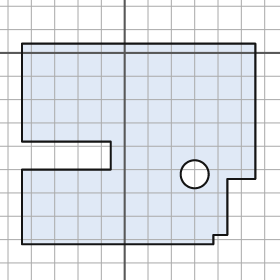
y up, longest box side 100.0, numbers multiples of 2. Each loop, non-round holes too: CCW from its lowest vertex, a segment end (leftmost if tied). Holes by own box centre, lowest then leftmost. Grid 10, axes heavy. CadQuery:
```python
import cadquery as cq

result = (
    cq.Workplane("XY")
    .moveTo(-44.0, -82.0)
    .lineTo(38.0, -82.0)
    .lineTo(38.0, -78.0)
    .lineTo(44.0, -78.0)
    .lineTo(44.0, -54.0)
    .lineTo(56.0, -54.0)
    .lineTo(56.0, 4.0)
    .lineTo(-44.0, 4.0)
    .lineTo(-44.0, -38.0)
    .lineTo(-6.0, -38.0)
    .lineTo(-6.0, -50.0)
    .lineTo(-44.0, -50.0)
    .close()
    .moveTo(30.0, -52.0)
    .circle(6.0)
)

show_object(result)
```